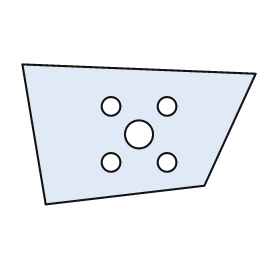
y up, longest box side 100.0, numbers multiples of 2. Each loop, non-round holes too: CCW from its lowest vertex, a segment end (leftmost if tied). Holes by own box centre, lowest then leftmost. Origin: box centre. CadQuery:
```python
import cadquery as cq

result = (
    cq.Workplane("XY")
    .moveTo(-40.0, -30.0)
    .lineTo(28.0, -22.0)
    .lineTo(50.0, 26.0)
    .lineTo(-50.0, 30.0)
    .close()
    .moveTo(-12.0, -12.0)
    .circle(4.0)
    .moveTo(12.0, -12.0)
    .circle(4.0)
    .moveTo(0.0, 0.0)
    .circle(6.0)
    .moveTo(-12.0, 12.0)
    .circle(4.0)
    .moveTo(12.0, 12.0)
    .circle(4.0)
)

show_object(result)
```